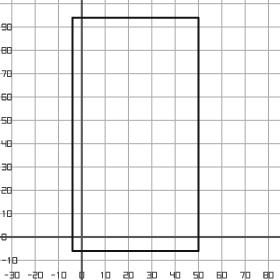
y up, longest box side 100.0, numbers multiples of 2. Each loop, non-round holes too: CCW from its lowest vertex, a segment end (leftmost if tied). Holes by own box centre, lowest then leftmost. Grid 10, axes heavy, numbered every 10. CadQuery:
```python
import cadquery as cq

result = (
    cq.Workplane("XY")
    .moveTo(-4.0, -6.0)
    .lineTo(50.0, -6.0)
    .lineTo(50.0, 94.0)
    .lineTo(-4.0, 94.0)
    .close()
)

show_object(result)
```